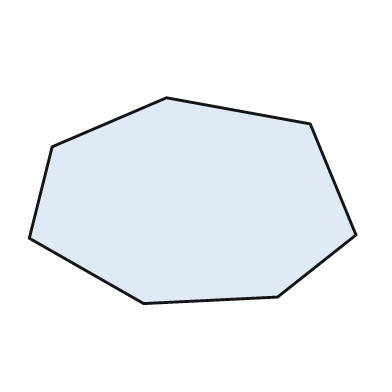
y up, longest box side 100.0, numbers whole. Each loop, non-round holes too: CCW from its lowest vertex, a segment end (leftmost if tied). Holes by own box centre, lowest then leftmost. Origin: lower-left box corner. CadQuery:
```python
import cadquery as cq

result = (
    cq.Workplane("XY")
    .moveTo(35.0, 0.0)
    .lineTo(76.0, 2.0)
    .lineTo(100.0, 21.0)
    .lineTo(86.0, 55.0)
    .lineTo(42.0, 63.0)
    .lineTo(7.0, 48.0)
    .lineTo(0.0, 20.0)
    .close()
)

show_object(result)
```